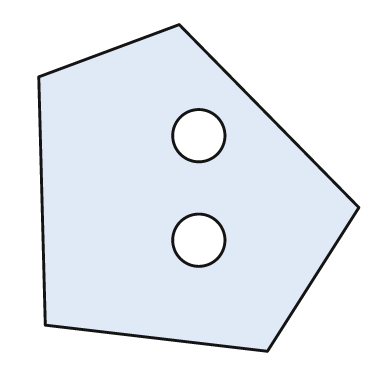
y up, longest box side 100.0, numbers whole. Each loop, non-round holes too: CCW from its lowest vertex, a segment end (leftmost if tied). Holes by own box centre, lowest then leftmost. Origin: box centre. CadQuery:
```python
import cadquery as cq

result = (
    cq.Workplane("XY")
    .moveTo(21.0, -50.0)
    .lineTo(49.0, -6.0)
    .lineTo(-6.0, 50.0)
    .lineTo(-49.0, 34.0)
    .lineTo(-47.0, -42.0)
    .close()
    .moveTo(0.0, -16.0)
    .circle(8.0)
    .moveTo(0.0, 16.0)
    .circle(8.0)
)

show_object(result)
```